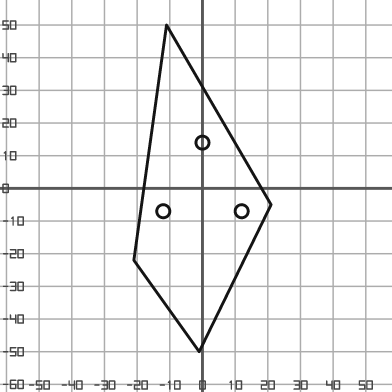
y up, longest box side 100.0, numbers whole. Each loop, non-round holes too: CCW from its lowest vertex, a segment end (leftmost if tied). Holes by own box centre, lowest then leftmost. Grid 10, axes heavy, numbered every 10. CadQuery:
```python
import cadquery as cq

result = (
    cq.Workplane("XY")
    .moveTo(-1.0, -50.0)
    .lineTo(21.0, -5.0)
    .lineTo(-11.0, 50.0)
    .lineTo(-21.0, -22.0)
    .close()
    .moveTo(-12.0, -7.0)
    .circle(2.0)
    .moveTo(12.0, -7.0)
    .circle(2.0)
    .moveTo(0.0, 14.0)
    .circle(2.0)
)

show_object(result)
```